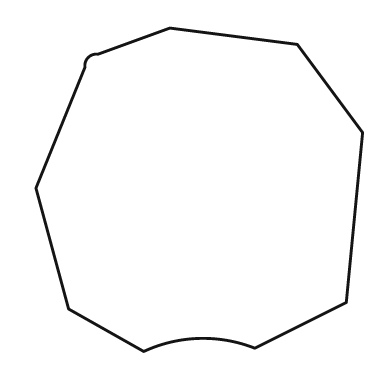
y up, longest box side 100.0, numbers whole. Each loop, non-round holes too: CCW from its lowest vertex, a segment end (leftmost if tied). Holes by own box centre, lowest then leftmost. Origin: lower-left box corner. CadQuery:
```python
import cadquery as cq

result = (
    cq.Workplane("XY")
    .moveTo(33.0, 0.0)
    .threePointArc((50.0, 4.0), (67.0, 1.0))
    .lineTo(95.0, 15.0)
    .lineTo(100.0, 67.0)
    .lineTo(80.0, 94.0)
    .lineTo(41.0, 99.0)
    .lineTo(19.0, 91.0)
    .threePointArc((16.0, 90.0), (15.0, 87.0))
    .lineTo(0.0, 50.0)
    .lineTo(10.0, 13.0)
    .close()
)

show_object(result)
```